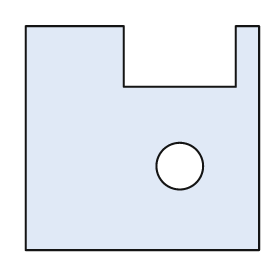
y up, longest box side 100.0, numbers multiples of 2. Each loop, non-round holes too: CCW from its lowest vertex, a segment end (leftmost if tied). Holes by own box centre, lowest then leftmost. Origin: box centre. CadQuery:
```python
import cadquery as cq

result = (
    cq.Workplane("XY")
    .moveTo(-50.0, -48.0)
    .lineTo(50.0, -48.0)
    .lineTo(50.0, 48.0)
    .lineTo(40.0, 48.0)
    .lineTo(40.0, 22.0)
    .lineTo(-8.0, 22.0)
    .lineTo(-8.0, 48.0)
    .lineTo(-50.0, 48.0)
    .close()
    .moveTo(16.0, -12.0)
    .circle(10.0)
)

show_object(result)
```